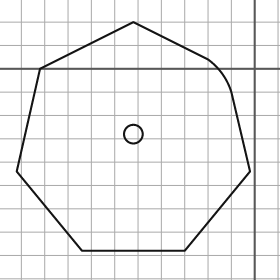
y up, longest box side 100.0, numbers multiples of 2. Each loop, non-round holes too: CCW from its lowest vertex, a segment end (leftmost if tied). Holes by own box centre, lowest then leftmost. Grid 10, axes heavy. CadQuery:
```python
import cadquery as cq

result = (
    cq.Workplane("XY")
    .moveTo(-74.0, -78.0)
    .lineTo(-30.0, -78.0)
    .lineTo(-2.0, -44.0)
    .lineTo(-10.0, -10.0)
    .threePointArc((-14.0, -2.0), (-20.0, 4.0))
    .lineTo(-52.0, 20.0)
    .lineTo(-92.0, 0.0)
    .lineTo(-102.0, -44.0)
    .close()
    .moveTo(-52.0, -28.0)
    .circle(4.0)
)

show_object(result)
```